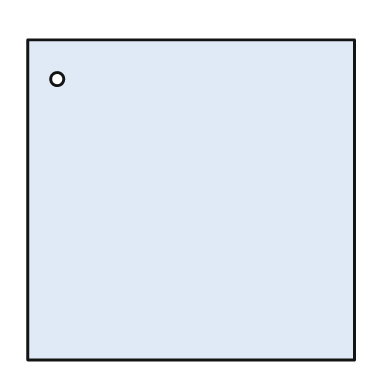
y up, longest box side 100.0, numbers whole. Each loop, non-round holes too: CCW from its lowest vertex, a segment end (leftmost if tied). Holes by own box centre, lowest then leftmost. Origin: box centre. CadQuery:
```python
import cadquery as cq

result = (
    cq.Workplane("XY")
    .moveTo(-50.0, -49.0)
    .lineTo(50.0, -49.0)
    .lineTo(50.0, 49.0)
    .lineTo(-50.0, 49.0)
    .close()
    .moveTo(-41.0, 37.0)
    .circle(2.0)
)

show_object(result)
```